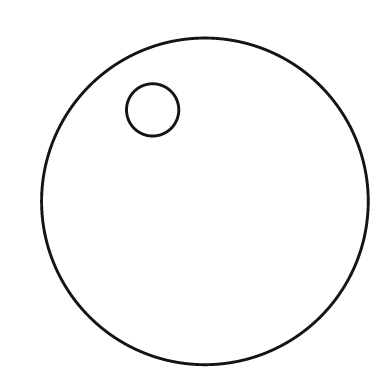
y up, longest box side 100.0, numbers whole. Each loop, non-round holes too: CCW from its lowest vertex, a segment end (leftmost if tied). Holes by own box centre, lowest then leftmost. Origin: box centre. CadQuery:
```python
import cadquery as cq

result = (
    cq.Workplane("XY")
    .moveTo(0.0, 0.0)
    .circle(50.0)
    .moveTo(-16.0, 28.0)
    .circle(8.0)
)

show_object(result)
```